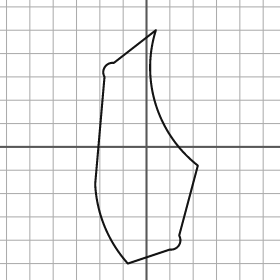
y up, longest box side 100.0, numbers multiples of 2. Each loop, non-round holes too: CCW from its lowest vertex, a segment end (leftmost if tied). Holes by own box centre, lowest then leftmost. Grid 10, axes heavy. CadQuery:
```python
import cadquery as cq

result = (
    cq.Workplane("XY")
    .moveTo(-8.0, -50.0)
    .lineTo(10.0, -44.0)
    .threePointArc((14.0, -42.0), (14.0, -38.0))
    .lineTo(22.0, -8.0)
    .threePointArc((4.0, 18.0), (4.0, 50.0))
    .lineTo(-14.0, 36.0)
    .threePointArc((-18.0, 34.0), (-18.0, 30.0))
    .lineTo(-22.0, -16.0)
    .threePointArc((-18.0, -34.0), (-8.0, -50.0))
    .close()
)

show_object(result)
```